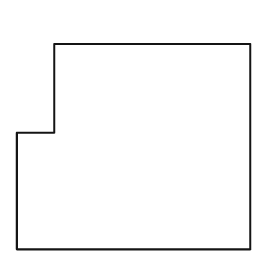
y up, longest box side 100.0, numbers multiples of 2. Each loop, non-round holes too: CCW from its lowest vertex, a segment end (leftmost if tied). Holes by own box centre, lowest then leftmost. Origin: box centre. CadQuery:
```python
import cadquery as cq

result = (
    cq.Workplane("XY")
    .moveTo(-50.0, -44.0)
    .lineTo(50.0, -44.0)
    .lineTo(50.0, 44.0)
    .lineTo(-34.0, 44.0)
    .lineTo(-34.0, 6.0)
    .lineTo(-50.0, 6.0)
    .close()
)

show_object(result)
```